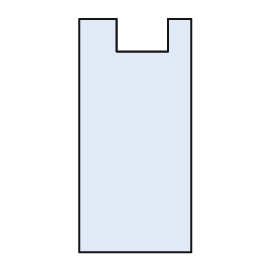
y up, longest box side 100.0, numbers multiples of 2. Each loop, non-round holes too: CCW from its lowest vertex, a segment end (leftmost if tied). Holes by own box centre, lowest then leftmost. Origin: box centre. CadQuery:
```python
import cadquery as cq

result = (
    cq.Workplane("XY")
    .moveTo(-24.0, -50.0)
    .lineTo(24.0, -50.0)
    .lineTo(24.0, 50.0)
    .lineTo(14.0, 50.0)
    .lineTo(14.0, 36.0)
    .lineTo(-8.0, 36.0)
    .lineTo(-8.0, 50.0)
    .lineTo(-24.0, 50.0)
    .close()
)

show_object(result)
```